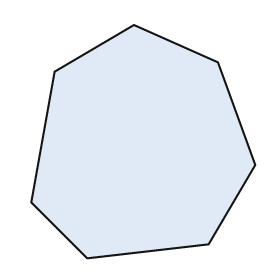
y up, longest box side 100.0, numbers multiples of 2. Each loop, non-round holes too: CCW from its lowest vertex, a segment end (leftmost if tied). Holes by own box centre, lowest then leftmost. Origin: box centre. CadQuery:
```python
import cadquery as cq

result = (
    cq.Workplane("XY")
    .moveTo(-24.0, -50.0)
    .lineTo(28.0, -44.0)
    .lineTo(48.0, -10.0)
    .lineTo(32.0, 34.0)
    .lineTo(-4.0, 50.0)
    .lineTo(-38.0, 30.0)
    .lineTo(-48.0, -26.0)
    .close()
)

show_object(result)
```